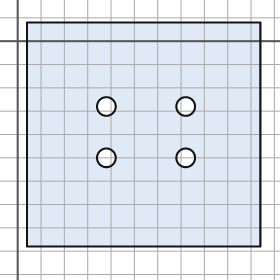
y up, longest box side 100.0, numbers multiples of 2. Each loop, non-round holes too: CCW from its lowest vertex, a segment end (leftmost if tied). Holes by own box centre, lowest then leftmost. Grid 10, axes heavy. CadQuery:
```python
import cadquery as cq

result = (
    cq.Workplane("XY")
    .moveTo(4.0, -88.0)
    .lineTo(104.0, -88.0)
    .lineTo(104.0, 8.0)
    .lineTo(4.0, 8.0)
    .close()
    .moveTo(38.0, -50.0)
    .circle(4.0)
    .moveTo(72.0, -50.0)
    .circle(4.0)
    .moveTo(38.0, -28.0)
    .circle(4.0)
    .moveTo(72.0, -28.0)
    .circle(4.0)
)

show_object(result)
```